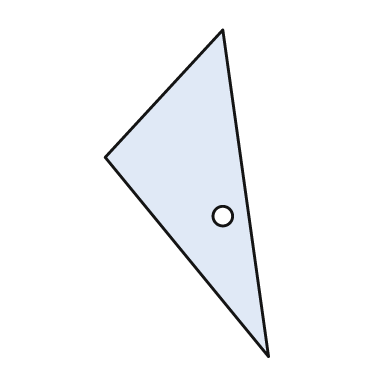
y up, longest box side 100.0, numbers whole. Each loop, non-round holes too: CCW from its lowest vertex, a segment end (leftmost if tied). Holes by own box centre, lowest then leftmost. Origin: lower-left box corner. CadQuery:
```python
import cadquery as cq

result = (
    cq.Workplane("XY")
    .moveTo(50.0, 0.0)
    .lineTo(36.0, 100.0)
    .lineTo(0.0, 61.0)
    .close()
    .moveTo(36.0, 43.0)
    .circle(3.0)
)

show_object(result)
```